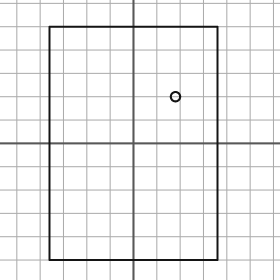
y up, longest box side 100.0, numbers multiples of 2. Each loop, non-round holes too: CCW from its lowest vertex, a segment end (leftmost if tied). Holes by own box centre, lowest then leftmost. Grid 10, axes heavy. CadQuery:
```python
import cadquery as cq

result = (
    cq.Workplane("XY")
    .moveTo(-36.0, -50.0)
    .lineTo(36.0, -50.0)
    .lineTo(36.0, 50.0)
    .lineTo(-36.0, 50.0)
    .close()
    .moveTo(18.0, 20.0)
    .circle(2.0)
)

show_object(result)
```